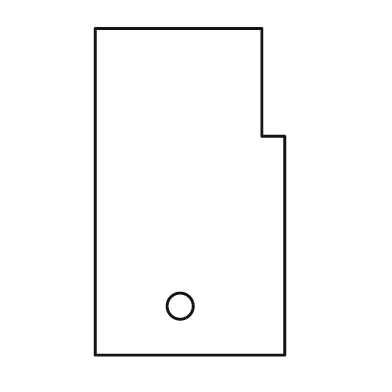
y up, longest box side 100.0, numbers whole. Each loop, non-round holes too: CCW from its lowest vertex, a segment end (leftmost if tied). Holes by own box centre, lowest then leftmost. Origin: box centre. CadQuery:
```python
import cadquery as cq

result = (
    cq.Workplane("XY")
    .moveTo(-29.0, -50.0)
    .lineTo(29.0, -50.0)
    .lineTo(29.0, 17.0)
    .lineTo(22.0, 17.0)
    .lineTo(22.0, 50.0)
    .lineTo(-29.0, 50.0)
    .close()
    .moveTo(-3.0, -35.0)
    .circle(4.0)
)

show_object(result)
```